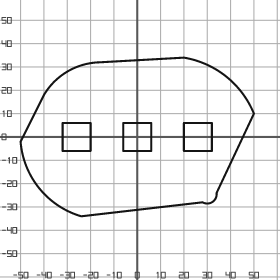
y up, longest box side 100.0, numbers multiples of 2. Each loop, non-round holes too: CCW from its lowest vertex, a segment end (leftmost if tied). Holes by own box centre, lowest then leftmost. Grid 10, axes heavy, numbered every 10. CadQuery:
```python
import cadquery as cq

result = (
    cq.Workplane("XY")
    .moveTo(-24.0, -34.0)
    .lineTo(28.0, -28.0)
    .threePointArc((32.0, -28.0), (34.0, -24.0))
    .lineTo(50.0, 10.0)
    .threePointArc((38.0, 26.0), (20.0, 34.0))
    .lineTo(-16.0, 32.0)
    .threePointArc((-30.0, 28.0), (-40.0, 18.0))
    .lineTo(-50.0, -2.0)
    .threePointArc((-42.0, -22.0), (-24.0, -34.0))
    .close()
    .moveTo(-32.0, -6.0)
    .lineTo(-20.0, -6.0)
    .lineTo(-20.0, 6.0)
    .lineTo(-32.0, 6.0)
    .close()
    .moveTo(-6.0, -6.0)
    .lineTo(6.0, -6.0)
    .lineTo(6.0, 6.0)
    .lineTo(-6.0, 6.0)
    .close()
    .moveTo(20.0, -6.0)
    .lineTo(32.0, -6.0)
    .lineTo(32.0, 6.0)
    .lineTo(20.0, 6.0)
    .close()
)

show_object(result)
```